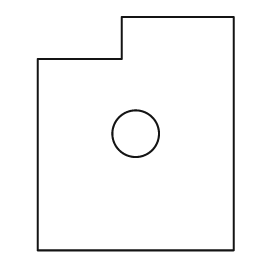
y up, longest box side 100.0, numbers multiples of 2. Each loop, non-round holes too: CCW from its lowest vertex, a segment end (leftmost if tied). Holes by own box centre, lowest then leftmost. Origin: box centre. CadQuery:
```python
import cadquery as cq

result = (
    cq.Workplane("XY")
    .moveTo(-42.0, -50.0)
    .lineTo(42.0, -50.0)
    .lineTo(42.0, 50.0)
    .lineTo(-6.0, 50.0)
    .lineTo(-6.0, 32.0)
    .lineTo(-42.0, 32.0)
    .close()
    .moveTo(0.0, 0.0)
    .circle(10.0)
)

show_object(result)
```